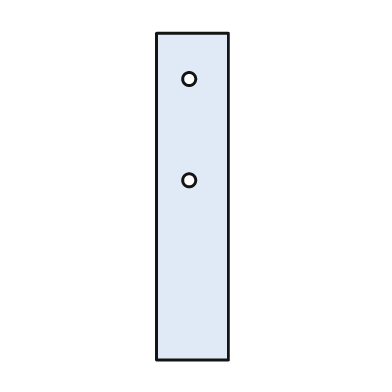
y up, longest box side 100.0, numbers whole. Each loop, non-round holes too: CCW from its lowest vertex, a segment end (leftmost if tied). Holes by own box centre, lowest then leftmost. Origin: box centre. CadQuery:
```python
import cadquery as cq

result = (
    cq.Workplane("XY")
    .moveTo(-11.0, -50.0)
    .lineTo(11.0, -50.0)
    .lineTo(11.0, 50.0)
    .lineTo(-11.0, 50.0)
    .close()
    .moveTo(-1.0, 5.0)
    .circle(2.0)
    .moveTo(-1.0, 36.0)
    .circle(2.0)
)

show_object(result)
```